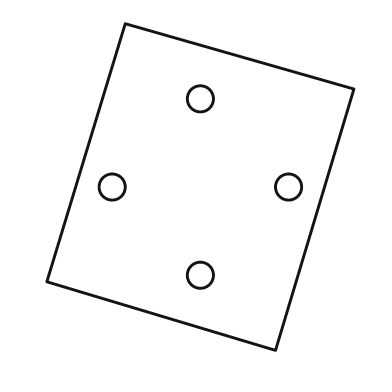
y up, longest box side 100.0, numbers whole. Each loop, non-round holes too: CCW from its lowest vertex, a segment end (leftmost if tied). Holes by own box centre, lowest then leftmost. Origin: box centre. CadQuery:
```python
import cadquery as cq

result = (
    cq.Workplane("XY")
    .moveTo(23.0, -50.0)
    .lineTo(47.0, 30.0)
    .lineTo(-23.0, 50.0)
    .lineTo(-47.0, -29.0)
    .close()
    .moveTo(0.0, -27.0)
    .circle(4.0)
    .moveTo(-27.0, 0.0)
    .circle(4.0)
    .moveTo(27.0, 0.0)
    .circle(4.0)
    .moveTo(0.0, 27.0)
    .circle(4.0)
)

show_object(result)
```